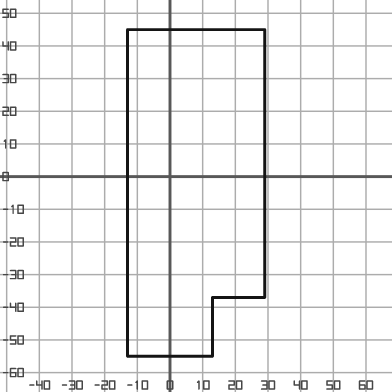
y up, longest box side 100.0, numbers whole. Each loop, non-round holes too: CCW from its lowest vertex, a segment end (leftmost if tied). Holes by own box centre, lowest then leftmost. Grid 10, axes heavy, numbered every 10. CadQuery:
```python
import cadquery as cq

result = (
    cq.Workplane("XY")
    .moveTo(-13.0, -55.0)
    .lineTo(13.0, -55.0)
    .lineTo(13.0, -37.0)
    .lineTo(29.0, -37.0)
    .lineTo(29.0, 45.0)
    .lineTo(-13.0, 45.0)
    .close()
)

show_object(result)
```